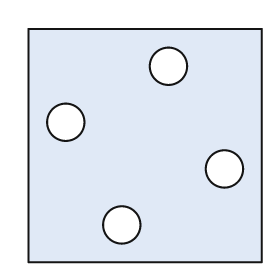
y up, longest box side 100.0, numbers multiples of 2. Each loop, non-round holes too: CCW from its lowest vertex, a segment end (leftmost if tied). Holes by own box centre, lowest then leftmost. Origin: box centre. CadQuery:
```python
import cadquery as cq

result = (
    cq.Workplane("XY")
    .moveTo(-50.0, -50.0)
    .lineTo(50.0, -50.0)
    .lineTo(50.0, 50.0)
    .lineTo(-50.0, 50.0)
    .close()
    .moveTo(-10.0, -34.0)
    .circle(8.0)
    .moveTo(34.0, -10.0)
    .circle(8.0)
    .moveTo(-34.0, 10.0)
    .circle(8.0)
    .moveTo(10.0, 34.0)
    .circle(8.0)
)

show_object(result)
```